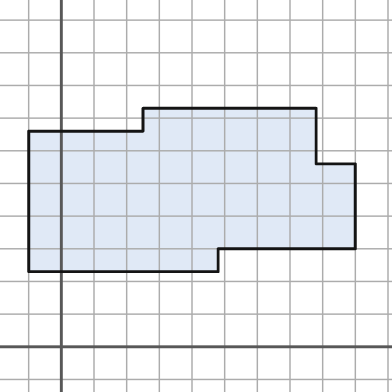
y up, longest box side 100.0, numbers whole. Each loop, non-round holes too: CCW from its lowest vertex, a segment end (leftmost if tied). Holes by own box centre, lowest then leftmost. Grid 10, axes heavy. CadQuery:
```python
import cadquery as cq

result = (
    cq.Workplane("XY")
    .moveTo(-10.0, 23.0)
    .lineTo(48.0, 23.0)
    .lineTo(48.0, 30.0)
    .lineTo(90.0, 30.0)
    .lineTo(90.0, 56.0)
    .lineTo(78.0, 56.0)
    .lineTo(78.0, 73.0)
    .lineTo(25.0, 73.0)
    .lineTo(25.0, 66.0)
    .lineTo(-10.0, 66.0)
    .close()
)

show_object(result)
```